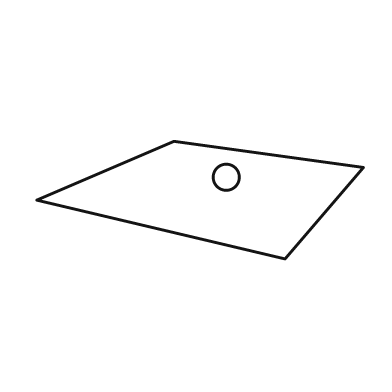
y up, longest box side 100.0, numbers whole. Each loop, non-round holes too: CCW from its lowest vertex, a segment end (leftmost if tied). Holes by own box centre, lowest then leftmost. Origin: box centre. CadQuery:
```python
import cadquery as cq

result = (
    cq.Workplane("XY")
    .moveTo(26.0, -18.0)
    .lineTo(50.0, 10.0)
    .lineTo(-8.0, 18.0)
    .lineTo(-50.0, 0.0)
    .close()
    .moveTo(8.0, 7.0)
    .circle(4.0)
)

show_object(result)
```